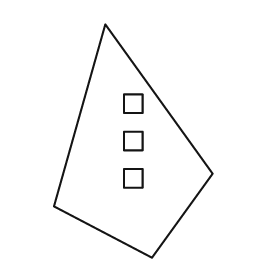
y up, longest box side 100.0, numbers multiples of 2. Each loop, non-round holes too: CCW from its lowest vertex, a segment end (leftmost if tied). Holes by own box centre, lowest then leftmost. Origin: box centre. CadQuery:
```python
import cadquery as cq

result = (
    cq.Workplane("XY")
    .moveTo(8.0, -50.0)
    .lineTo(34.0, -14.0)
    .lineTo(-12.0, 50.0)
    .lineTo(-34.0, -28.0)
    .close()
    .moveTo(-4.0, -20.0)
    .lineTo(4.0, -20.0)
    .lineTo(4.0, -12.0)
    .lineTo(-4.0, -12.0)
    .close()
    .moveTo(-4.0, -4.0)
    .lineTo(4.0, -4.0)
    .lineTo(4.0, 4.0)
    .lineTo(-4.0, 4.0)
    .close()
    .moveTo(-4.0, 12.0)
    .lineTo(4.0, 12.0)
    .lineTo(4.0, 20.0)
    .lineTo(-4.0, 20.0)
    .close()
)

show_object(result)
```